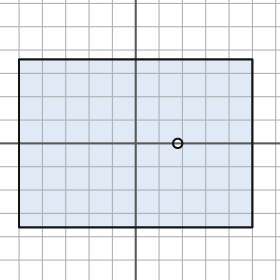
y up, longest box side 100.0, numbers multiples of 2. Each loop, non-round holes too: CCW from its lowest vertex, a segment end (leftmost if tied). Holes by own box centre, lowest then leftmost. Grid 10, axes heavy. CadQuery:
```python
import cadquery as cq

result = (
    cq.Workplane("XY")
    .moveTo(-50.0, -36.0)
    .lineTo(50.0, -36.0)
    .lineTo(50.0, 36.0)
    .lineTo(-50.0, 36.0)
    .close()
    .moveTo(18.0, 0.0)
    .circle(2.0)
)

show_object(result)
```